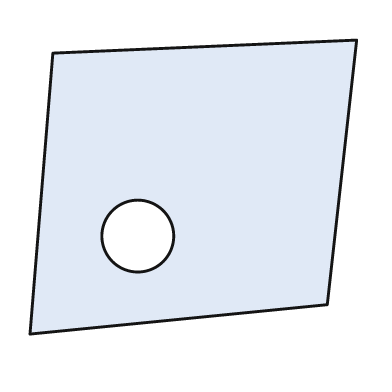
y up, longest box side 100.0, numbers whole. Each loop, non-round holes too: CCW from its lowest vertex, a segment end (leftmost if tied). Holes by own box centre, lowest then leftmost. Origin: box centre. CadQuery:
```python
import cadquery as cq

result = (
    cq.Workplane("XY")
    .moveTo(-50.0, -45.0)
    .lineTo(41.0, -36.0)
    .lineTo(50.0, 45.0)
    .lineTo(-43.0, 41.0)
    .close()
    .moveTo(-17.0, -15.0)
    .circle(11.0)
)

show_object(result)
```